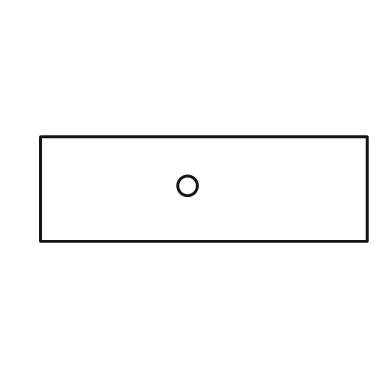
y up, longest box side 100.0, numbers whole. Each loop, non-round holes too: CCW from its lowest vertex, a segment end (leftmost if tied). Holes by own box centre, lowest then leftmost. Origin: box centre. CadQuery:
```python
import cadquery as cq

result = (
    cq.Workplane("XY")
    .moveTo(-50.0, -16.0)
    .lineTo(50.0, -16.0)
    .lineTo(50.0, 16.0)
    .lineTo(-50.0, 16.0)
    .close()
    .moveTo(-5.0, 1.0)
    .circle(3.0)
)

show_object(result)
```